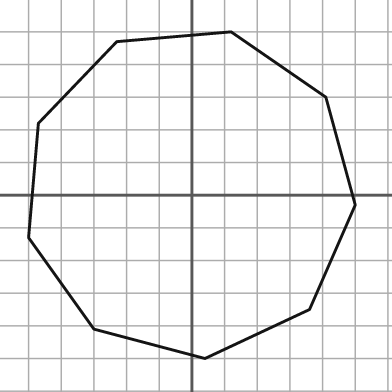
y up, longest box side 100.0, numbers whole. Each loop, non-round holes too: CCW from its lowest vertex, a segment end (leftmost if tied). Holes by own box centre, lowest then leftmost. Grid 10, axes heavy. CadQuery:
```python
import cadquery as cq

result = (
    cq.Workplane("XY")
    .moveTo(4.0, -50.0)
    .lineTo(36.0, -35.0)
    .lineTo(50.0, -3.0)
    .lineTo(41.0, 30.0)
    .lineTo(12.0, 50.0)
    .lineTo(-23.0, 47.0)
    .lineTo(-47.0, 22.0)
    .lineTo(-50.0, -13.0)
    .lineTo(-30.0, -41.0)
    .close()
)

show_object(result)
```